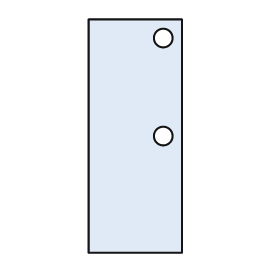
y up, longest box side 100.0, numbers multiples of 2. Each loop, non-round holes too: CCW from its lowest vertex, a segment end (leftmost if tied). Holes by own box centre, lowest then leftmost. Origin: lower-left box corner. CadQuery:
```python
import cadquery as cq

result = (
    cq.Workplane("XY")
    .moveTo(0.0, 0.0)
    .lineTo(40.0, 0.0)
    .lineTo(40.0, 100.0)
    .lineTo(0.0, 100.0)
    .close()
    .moveTo(32.0, 50.0)
    .circle(4.0)
    .moveTo(32.0, 92.0)
    .circle(4.0)
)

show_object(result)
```